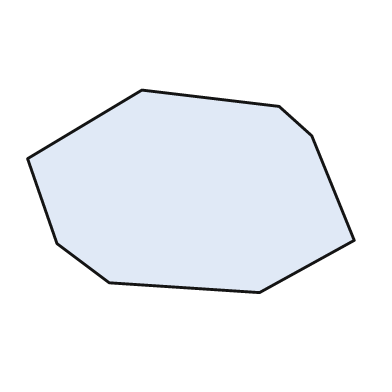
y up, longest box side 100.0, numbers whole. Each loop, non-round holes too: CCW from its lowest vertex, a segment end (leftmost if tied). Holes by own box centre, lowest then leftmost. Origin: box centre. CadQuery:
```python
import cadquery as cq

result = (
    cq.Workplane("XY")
    .moveTo(21.0, -31.0)
    .lineTo(50.0, -15.0)
    .lineTo(37.0, 17.0)
    .lineTo(27.0, 26.0)
    .lineTo(-15.0, 31.0)
    .lineTo(-50.0, 10.0)
    .lineTo(-41.0, -16.0)
    .lineTo(-25.0, -28.0)
    .close()
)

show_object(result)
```